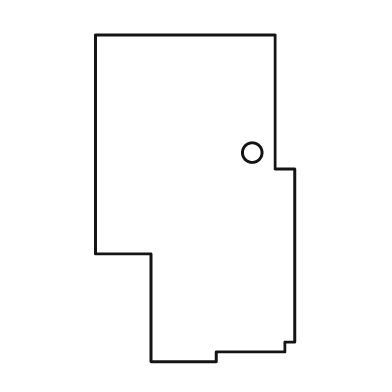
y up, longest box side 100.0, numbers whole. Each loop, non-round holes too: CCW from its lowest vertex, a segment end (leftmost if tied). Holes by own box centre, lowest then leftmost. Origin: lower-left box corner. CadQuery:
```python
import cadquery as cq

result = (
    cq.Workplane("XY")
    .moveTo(17.0, 0.0)
    .lineTo(37.0, 0.0)
    .lineTo(37.0, 3.0)
    .lineTo(58.0, 3.0)
    .lineTo(58.0, 6.0)
    .lineTo(61.0, 6.0)
    .lineTo(61.0, 59.0)
    .lineTo(55.0, 59.0)
    .lineTo(55.0, 100.0)
    .lineTo(0.0, 100.0)
    .lineTo(0.0, 33.0)
    .lineTo(17.0, 33.0)
    .close()
    .moveTo(48.0, 64.0)
    .circle(3.0)
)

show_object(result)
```